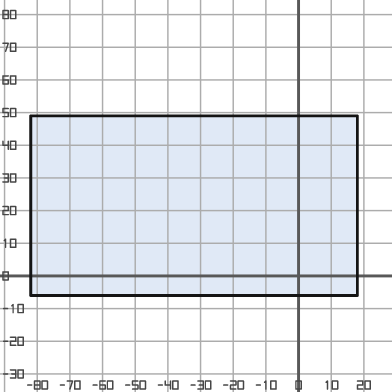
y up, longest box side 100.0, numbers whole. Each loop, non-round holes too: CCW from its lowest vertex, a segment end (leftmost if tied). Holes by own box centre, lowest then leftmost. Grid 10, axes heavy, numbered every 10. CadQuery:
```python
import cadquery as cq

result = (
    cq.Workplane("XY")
    .moveTo(-82.0, -6.0)
    .lineTo(18.0, -6.0)
    .lineTo(18.0, 49.0)
    .lineTo(-82.0, 49.0)
    .close()
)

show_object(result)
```